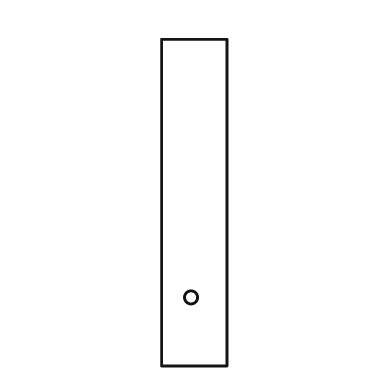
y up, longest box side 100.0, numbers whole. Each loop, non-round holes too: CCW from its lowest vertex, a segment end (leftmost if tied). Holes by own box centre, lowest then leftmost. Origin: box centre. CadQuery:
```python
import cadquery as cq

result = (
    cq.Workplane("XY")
    .moveTo(-10.0, -50.0)
    .lineTo(10.0, -50.0)
    .lineTo(10.0, 50.0)
    .lineTo(-10.0, 50.0)
    .close()
    .moveTo(-1.0, -29.0)
    .circle(2.0)
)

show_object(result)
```